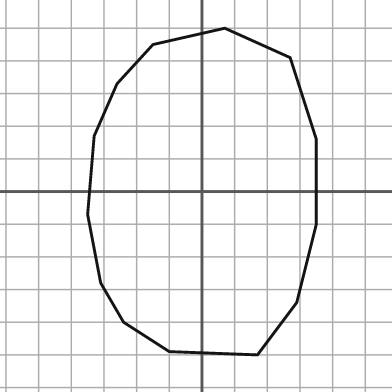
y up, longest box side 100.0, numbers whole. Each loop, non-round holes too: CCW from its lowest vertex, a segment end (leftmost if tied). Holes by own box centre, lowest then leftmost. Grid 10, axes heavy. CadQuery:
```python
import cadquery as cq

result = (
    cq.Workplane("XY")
    .moveTo(17.0, -50.0)
    .lineTo(29.0, -34.0)
    .lineTo(35.0, -10.0)
    .lineTo(35.0, 16.0)
    .lineTo(27.0, 41.0)
    .lineTo(7.0, 50.0)
    .lineTo(-15.0, 45.0)
    .lineTo(-26.0, 33.0)
    .lineTo(-33.0, 17.0)
    .lineTo(-35.0, -7.0)
    .lineTo(-31.0, -28.0)
    .lineTo(-24.0, -40.0)
    .lineTo(-10.0, -49.0)
    .close()
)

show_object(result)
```